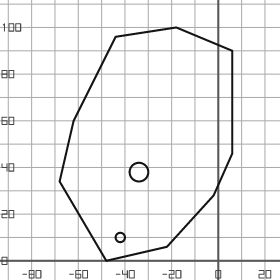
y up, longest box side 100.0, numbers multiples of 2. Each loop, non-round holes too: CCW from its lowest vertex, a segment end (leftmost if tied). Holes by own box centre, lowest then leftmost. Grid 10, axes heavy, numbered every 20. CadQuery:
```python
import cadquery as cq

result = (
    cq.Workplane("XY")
    .moveTo(-48.0, 0.0)
    .lineTo(-22.0, 6.0)
    .lineTo(-2.0, 28.0)
    .lineTo(6.0, 46.0)
    .lineTo(6.0, 90.0)
    .lineTo(-18.0, 100.0)
    .lineTo(-44.0, 96.0)
    .lineTo(-62.0, 60.0)
    .lineTo(-68.0, 34.0)
    .close()
    .moveTo(-42.0, 10.0)
    .circle(2.0)
    .moveTo(-34.0, 38.0)
    .circle(4.0)
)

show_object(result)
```